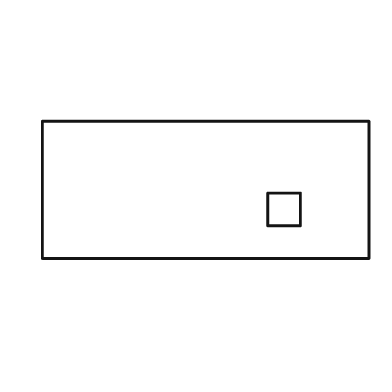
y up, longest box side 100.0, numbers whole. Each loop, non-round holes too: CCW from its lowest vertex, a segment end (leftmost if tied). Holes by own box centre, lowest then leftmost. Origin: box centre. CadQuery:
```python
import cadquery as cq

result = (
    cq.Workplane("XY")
    .moveTo(-50.0, -21.0)
    .lineTo(50.0, -21.0)
    .lineTo(50.0, 21.0)
    .lineTo(-50.0, 21.0)
    .close()
    .moveTo(19.0, -11.0)
    .lineTo(29.0, -11.0)
    .lineTo(29.0, -1.0)
    .lineTo(19.0, -1.0)
    .close()
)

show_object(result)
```